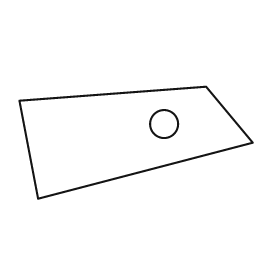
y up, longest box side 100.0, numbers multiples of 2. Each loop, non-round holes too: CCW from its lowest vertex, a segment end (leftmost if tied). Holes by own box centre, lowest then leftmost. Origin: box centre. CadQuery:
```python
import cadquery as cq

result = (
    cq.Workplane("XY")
    .moveTo(-42.0, -24.0)
    .lineTo(50.0, 0.0)
    .lineTo(30.0, 24.0)
    .lineTo(-50.0, 18.0)
    .close()
    .moveTo(12.0, 8.0)
    .circle(6.0)
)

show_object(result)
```